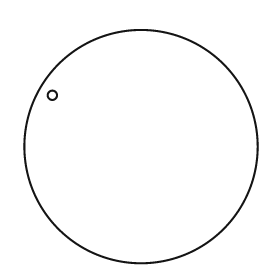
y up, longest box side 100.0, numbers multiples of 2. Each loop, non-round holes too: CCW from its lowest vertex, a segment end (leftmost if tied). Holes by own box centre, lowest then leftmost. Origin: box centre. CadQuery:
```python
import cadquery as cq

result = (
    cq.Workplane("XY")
    .moveTo(0.0, 0.0)
    .circle(50.0)
    .moveTo(-38.0, 22.0)
    .circle(2.0)
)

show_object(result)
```